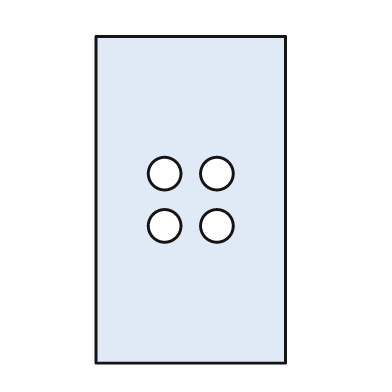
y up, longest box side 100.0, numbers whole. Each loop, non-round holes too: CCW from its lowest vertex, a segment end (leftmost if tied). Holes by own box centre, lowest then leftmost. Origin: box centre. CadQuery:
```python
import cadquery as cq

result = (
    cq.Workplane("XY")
    .moveTo(-29.0, -50.0)
    .lineTo(29.0, -50.0)
    .lineTo(29.0, 50.0)
    .lineTo(-29.0, 50.0)
    .close()
    .moveTo(-8.0, -8.0)
    .circle(5.0)
    .moveTo(8.0, -8.0)
    .circle(5.0)
    .moveTo(-8.0, 8.0)
    .circle(5.0)
    .moveTo(8.0, 8.0)
    .circle(5.0)
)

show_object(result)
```